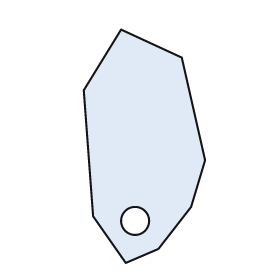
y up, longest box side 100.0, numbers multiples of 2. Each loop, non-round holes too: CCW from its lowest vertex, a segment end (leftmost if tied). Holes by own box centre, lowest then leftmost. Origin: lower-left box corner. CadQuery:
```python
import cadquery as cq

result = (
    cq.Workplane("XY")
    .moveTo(18.0, 0.0)
    .lineTo(32.0, 6.0)
    .lineTo(46.0, 24.0)
    .lineTo(52.0, 44.0)
    .lineTo(42.0, 88.0)
    .lineTo(16.0, 100.0)
    .lineTo(0.0, 74.0)
    .lineTo(4.0, 20.0)
    .close()
    .moveTo(22.0, 18.0)
    .circle(6.0)
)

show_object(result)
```